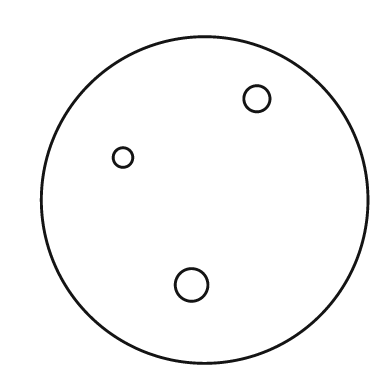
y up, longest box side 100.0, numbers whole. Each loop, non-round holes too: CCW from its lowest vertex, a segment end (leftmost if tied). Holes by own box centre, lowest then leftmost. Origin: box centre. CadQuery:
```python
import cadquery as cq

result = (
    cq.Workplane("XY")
    .moveTo(0.0, 0.0)
    .circle(50.0)
    .moveTo(-4.0, -26.0)
    .circle(5.0)
    .moveTo(-25.0, 13.0)
    .circle(3.0)
    .moveTo(16.0, 31.0)
    .circle(4.0)
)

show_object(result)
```